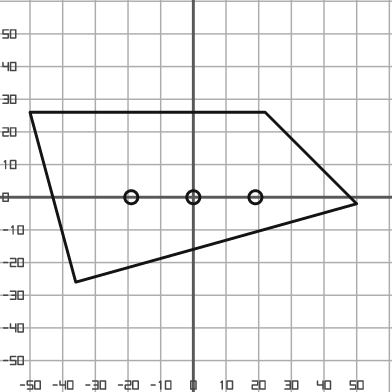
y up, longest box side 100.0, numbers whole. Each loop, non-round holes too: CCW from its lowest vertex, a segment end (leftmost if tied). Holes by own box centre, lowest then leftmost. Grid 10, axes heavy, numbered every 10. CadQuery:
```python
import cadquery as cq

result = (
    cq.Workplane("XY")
    .moveTo(-36.0, -26.0)
    .lineTo(50.0, -2.0)
    .lineTo(22.0, 26.0)
    .lineTo(-50.0, 26.0)
    .close()
    .moveTo(-19.0, 0.0)
    .circle(2.0)
    .moveTo(0.0, 0.0)
    .circle(2.0)
    .moveTo(19.0, 0.0)
    .circle(2.0)
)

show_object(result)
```